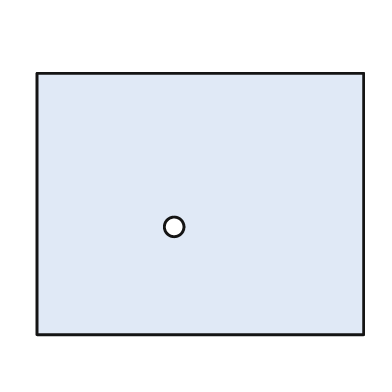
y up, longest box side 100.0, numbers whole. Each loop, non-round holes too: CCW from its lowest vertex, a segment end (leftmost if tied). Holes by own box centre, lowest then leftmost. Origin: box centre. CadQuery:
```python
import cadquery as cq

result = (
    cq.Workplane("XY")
    .moveTo(-50.0, -40.0)
    .lineTo(50.0, -40.0)
    .lineTo(50.0, 40.0)
    .lineTo(-50.0, 40.0)
    .close()
    .moveTo(-8.0, -7.0)
    .circle(3.0)
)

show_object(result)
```